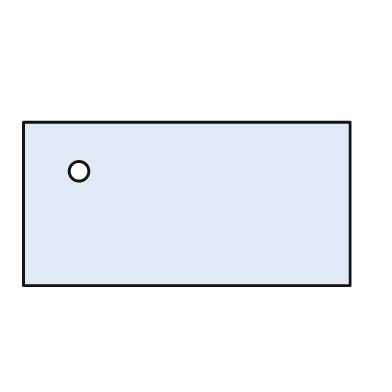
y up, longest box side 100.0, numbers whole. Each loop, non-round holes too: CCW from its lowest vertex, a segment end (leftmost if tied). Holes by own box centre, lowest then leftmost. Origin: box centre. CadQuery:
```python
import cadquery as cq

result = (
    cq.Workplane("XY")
    .moveTo(-50.0, -25.0)
    .lineTo(50.0, -25.0)
    .lineTo(50.0, 25.0)
    .lineTo(-50.0, 25.0)
    .close()
    .moveTo(-33.0, 10.0)
    .circle(3.0)
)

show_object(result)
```